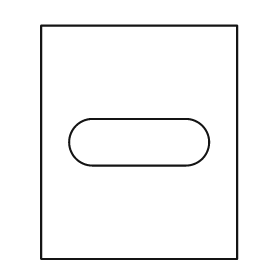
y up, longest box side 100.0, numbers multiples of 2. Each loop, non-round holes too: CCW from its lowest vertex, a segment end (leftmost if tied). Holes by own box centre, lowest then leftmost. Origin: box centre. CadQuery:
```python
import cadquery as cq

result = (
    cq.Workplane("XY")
    .moveTo(-42.0, -50.0)
    .lineTo(42.0, -50.0)
    .lineTo(42.0, 50.0)
    .lineTo(-42.0, 50.0)
    .close()
    .moveTo(-20.0, -10.0)
    .lineTo(20.0, -10.0)
    .threePointArc((30.0, 0.0), (20.0, 10.0))
    .lineTo(-20.0, 10.0)
    .threePointArc((-30.0, 0.0), (-20.0, -10.0))
    .close()
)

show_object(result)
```